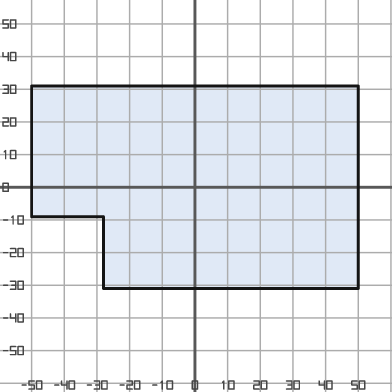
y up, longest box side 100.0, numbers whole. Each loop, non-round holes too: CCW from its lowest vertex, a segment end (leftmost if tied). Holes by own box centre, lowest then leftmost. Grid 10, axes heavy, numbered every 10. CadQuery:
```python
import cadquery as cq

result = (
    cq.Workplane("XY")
    .moveTo(-28.0, -31.0)
    .lineTo(50.0, -31.0)
    .lineTo(50.0, 31.0)
    .lineTo(-50.0, 31.0)
    .lineTo(-50.0, -9.0)
    .lineTo(-28.0, -9.0)
    .close()
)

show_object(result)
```